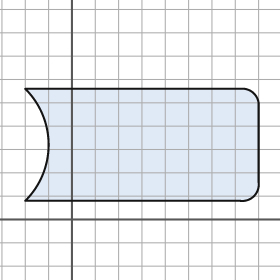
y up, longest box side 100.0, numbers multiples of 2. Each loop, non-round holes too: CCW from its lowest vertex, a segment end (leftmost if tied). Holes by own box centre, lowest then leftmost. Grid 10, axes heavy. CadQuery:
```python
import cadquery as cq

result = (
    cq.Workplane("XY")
    .moveTo(-20.0, 8.0)
    .lineTo(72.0, 8.0)
    .threePointArc((78.0, 10.0), (80.0, 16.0))
    .lineTo(80.0, 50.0)
    .threePointArc((78.0, 54.0), (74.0, 56.0))
    .lineTo(-20.0, 56.0)
    .threePointArc((-10.0, 32.0), (-20.0, 8.0))
    .close()
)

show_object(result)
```